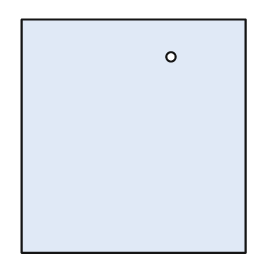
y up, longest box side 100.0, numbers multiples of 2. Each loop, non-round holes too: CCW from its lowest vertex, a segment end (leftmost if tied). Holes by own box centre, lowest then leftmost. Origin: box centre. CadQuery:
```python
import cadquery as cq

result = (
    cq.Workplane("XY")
    .moveTo(-48.0, -50.0)
    .lineTo(48.0, -50.0)
    .lineTo(48.0, 50.0)
    .lineTo(-48.0, 50.0)
    .close()
    .moveTo(16.0, 34.0)
    .circle(2.0)
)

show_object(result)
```